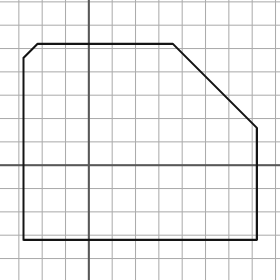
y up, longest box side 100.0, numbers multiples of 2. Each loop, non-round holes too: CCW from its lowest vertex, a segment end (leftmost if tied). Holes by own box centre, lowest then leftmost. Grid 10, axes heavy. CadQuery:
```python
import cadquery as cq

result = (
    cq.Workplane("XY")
    .moveTo(-28.0, -32.0)
    .lineTo(72.0, -32.0)
    .lineTo(72.0, 16.0)
    .lineTo(36.0, 52.0)
    .lineTo(-22.0, 52.0)
    .lineTo(-28.0, 46.0)
    .close()
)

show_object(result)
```